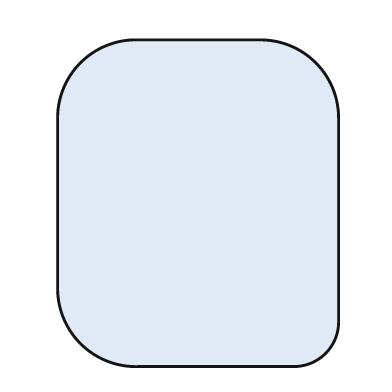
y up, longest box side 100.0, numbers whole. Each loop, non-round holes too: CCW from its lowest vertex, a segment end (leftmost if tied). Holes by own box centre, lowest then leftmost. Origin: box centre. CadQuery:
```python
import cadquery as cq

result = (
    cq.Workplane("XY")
    .moveTo(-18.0, -50.0)
    .lineTo(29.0, -50.0)
    .threePointArc((39.0, -46.0), (43.0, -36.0))
    .lineTo(43.0, 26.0)
    .threePointArc((36.0, 43.0), (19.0, 50.0))
    .lineTo(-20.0, 50.0)
    .threePointArc((-36.0, 43.0), (-43.0, 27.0))
    .lineTo(-43.0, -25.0)
    .threePointArc((-36.0, -43.0), (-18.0, -50.0))
    .close()
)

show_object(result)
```